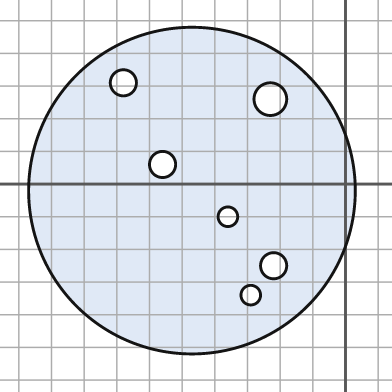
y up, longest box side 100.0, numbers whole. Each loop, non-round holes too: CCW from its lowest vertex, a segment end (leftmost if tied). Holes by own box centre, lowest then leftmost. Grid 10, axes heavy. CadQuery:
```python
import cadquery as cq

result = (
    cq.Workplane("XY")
    .moveTo(-47.0, -2.0)
    .circle(50.0)
    .moveTo(-29.0, -34.0)
    .circle(3.0)
    .moveTo(-22.0, -25.0)
    .circle(4.0)
    .moveTo(-36.0, -10.0)
    .circle(3.0)
    .moveTo(-56.0, 6.0)
    .circle(4.0)
    .moveTo(-23.0, 26.0)
    .circle(5.0)
    .moveTo(-68.0, 31.0)
    .circle(4.0)
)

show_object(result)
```